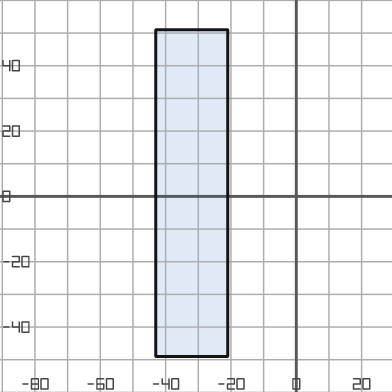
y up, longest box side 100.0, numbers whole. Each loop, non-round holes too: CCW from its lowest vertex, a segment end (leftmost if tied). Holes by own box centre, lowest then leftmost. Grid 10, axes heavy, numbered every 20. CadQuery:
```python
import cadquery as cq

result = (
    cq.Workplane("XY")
    .moveTo(-43.0, -49.0)
    .lineTo(-21.0, -49.0)
    .lineTo(-21.0, 51.0)
    .lineTo(-43.0, 51.0)
    .close()
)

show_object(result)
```